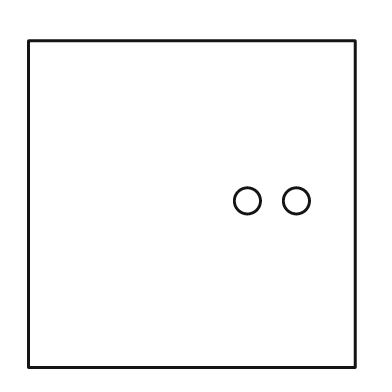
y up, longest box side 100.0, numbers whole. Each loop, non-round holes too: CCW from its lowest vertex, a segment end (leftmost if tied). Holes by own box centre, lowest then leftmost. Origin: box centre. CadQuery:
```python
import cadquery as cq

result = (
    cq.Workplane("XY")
    .moveTo(-50.0, -50.0)
    .lineTo(50.0, -50.0)
    .lineTo(50.0, 50.0)
    .lineTo(-50.0, 50.0)
    .close()
    .moveTo(17.0, 1.0)
    .circle(4.0)
    .moveTo(32.0, 1.0)
    .circle(4.0)
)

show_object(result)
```